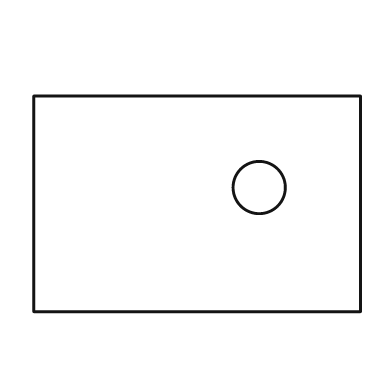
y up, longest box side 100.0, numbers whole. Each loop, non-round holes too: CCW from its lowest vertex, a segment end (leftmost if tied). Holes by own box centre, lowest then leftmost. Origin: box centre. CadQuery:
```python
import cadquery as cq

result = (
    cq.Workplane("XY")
    .moveTo(-50.0, -33.0)
    .lineTo(50.0, -33.0)
    .lineTo(50.0, 33.0)
    .lineTo(-50.0, 33.0)
    .close()
    .moveTo(19.0, 5.0)
    .circle(8.0)
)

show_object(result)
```